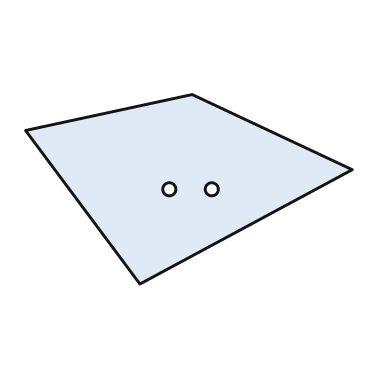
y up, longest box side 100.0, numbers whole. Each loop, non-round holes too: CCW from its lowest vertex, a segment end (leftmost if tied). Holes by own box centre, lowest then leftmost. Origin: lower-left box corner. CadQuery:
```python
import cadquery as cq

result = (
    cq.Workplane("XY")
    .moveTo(35.0, 0.0)
    .lineTo(100.0, 35.0)
    .lineTo(51.0, 58.0)
    .lineTo(0.0, 47.0)
    .close()
    .moveTo(44.0, 29.0)
    .circle(2.0)
    .moveTo(57.0, 29.0)
    .circle(2.0)
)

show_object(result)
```